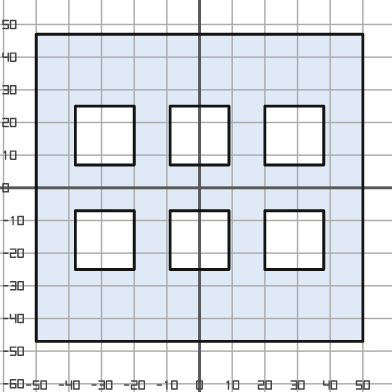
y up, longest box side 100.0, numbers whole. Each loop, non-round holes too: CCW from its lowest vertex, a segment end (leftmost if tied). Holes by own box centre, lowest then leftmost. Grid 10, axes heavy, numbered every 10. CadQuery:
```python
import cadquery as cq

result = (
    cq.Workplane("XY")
    .moveTo(-50.0, -47.0)
    .lineTo(50.0, -47.0)
    .lineTo(50.0, 47.0)
    .lineTo(-50.0, 47.0)
    .close()
    .moveTo(-38.0, -25.0)
    .lineTo(-20.0, -25.0)
    .lineTo(-20.0, -7.0)
    .lineTo(-38.0, -7.0)
    .close()
    .moveTo(-9.0, -25.0)
    .lineTo(9.0, -25.0)
    .lineTo(9.0, -7.0)
    .lineTo(-9.0, -7.0)
    .close()
    .moveTo(20.0, -25.0)
    .lineTo(38.0, -25.0)
    .lineTo(38.0, -7.0)
    .lineTo(20.0, -7.0)
    .close()
    .moveTo(-38.0, 7.0)
    .lineTo(-20.0, 7.0)
    .lineTo(-20.0, 25.0)
    .lineTo(-38.0, 25.0)
    .close()
    .moveTo(-9.0, 7.0)
    .lineTo(9.0, 7.0)
    .lineTo(9.0, 25.0)
    .lineTo(-9.0, 25.0)
    .close()
    .moveTo(20.0, 7.0)
    .lineTo(38.0, 7.0)
    .lineTo(38.0, 25.0)
    .lineTo(20.0, 25.0)
    .close()
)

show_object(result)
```